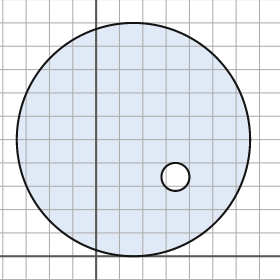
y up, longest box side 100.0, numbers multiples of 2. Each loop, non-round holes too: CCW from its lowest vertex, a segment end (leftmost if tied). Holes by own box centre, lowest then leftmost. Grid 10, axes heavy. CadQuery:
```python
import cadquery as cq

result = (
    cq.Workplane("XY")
    .moveTo(16.0, 50.0)
    .circle(50.0)
    .moveTo(34.0, 34.0)
    .circle(6.0)
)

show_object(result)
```